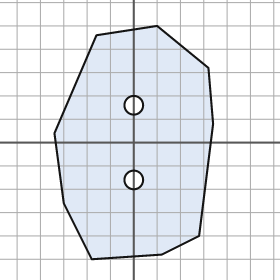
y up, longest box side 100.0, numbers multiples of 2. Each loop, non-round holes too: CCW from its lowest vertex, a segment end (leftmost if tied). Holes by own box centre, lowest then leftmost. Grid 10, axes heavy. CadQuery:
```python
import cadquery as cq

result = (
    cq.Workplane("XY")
    .moveTo(-18.0, -50.0)
    .lineTo(12.0, -48.0)
    .lineTo(28.0, -40.0)
    .lineTo(34.0, 8.0)
    .lineTo(32.0, 32.0)
    .lineTo(10.0, 50.0)
    .lineTo(-16.0, 46.0)
    .lineTo(-34.0, 4.0)
    .lineTo(-30.0, -26.0)
    .close()
    .moveTo(0.0, -16.0)
    .circle(4.0)
    .moveTo(0.0, 16.0)
    .circle(4.0)
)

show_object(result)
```